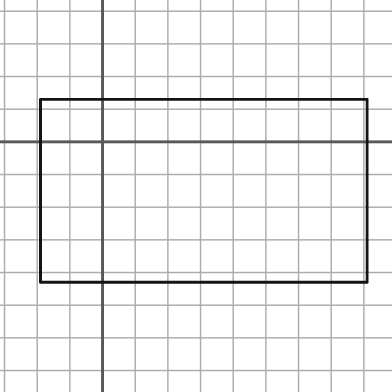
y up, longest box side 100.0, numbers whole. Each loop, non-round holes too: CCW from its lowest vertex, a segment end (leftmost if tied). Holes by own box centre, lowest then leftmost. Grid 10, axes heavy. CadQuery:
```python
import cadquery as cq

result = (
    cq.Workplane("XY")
    .moveTo(-19.0, -43.0)
    .lineTo(81.0, -43.0)
    .lineTo(81.0, 13.0)
    .lineTo(-19.0, 13.0)
    .close()
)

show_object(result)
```